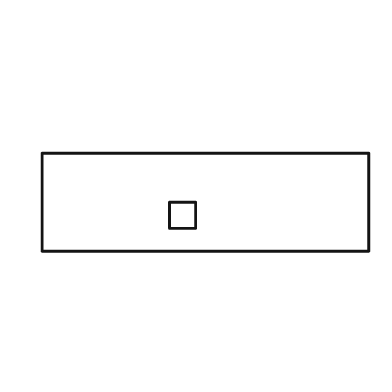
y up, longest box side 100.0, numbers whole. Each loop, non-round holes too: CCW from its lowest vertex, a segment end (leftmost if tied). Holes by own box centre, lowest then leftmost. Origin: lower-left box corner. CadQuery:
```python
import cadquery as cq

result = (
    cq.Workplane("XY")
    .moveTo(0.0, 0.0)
    .lineTo(100.0, 0.0)
    .lineTo(100.0, 30.0)
    .lineTo(0.0, 30.0)
    .close()
    .moveTo(39.0, 7.0)
    .lineTo(47.0, 7.0)
    .lineTo(47.0, 15.0)
    .lineTo(39.0, 15.0)
    .close()
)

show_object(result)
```